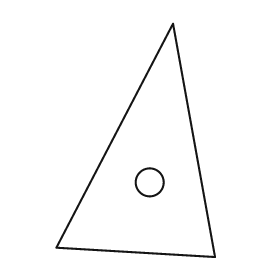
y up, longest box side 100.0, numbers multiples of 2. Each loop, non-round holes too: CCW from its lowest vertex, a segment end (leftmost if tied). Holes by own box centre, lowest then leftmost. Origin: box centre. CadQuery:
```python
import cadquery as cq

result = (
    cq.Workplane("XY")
    .moveTo(34.0, -50.0)
    .lineTo(16.0, 50.0)
    .lineTo(-34.0, -46.0)
    .close()
    .moveTo(6.0, -18.0)
    .circle(6.0)
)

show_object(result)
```